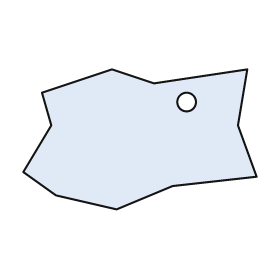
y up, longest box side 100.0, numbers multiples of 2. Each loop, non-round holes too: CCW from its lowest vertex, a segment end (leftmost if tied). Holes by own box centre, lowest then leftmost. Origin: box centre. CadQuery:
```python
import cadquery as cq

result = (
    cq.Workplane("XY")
    .moveTo(-10.0, -30.0)
    .lineTo(14.0, -20.0)
    .lineTo(50.0, -16.0)
    .lineTo(42.0, 6.0)
    .lineTo(46.0, 30.0)
    .lineTo(6.0, 24.0)
    .lineTo(-12.0, 30.0)
    .lineTo(-42.0, 20.0)
    .lineTo(-38.0, 6.0)
    .lineTo(-50.0, -14.0)
    .lineTo(-36.0, -24.0)
    .close()
    .moveTo(20.0, 16.0)
    .circle(4.0)
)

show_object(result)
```